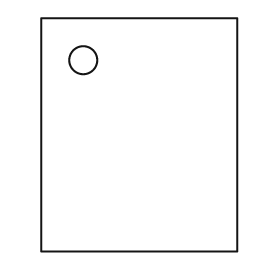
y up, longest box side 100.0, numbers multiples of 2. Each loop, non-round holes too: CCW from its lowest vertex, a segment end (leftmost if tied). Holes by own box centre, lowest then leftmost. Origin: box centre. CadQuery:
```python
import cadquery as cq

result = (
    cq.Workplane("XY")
    .moveTo(-42.0, -50.0)
    .lineTo(42.0, -50.0)
    .lineTo(42.0, 50.0)
    .lineTo(-42.0, 50.0)
    .close()
    .moveTo(-24.0, 32.0)
    .circle(6.0)
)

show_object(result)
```